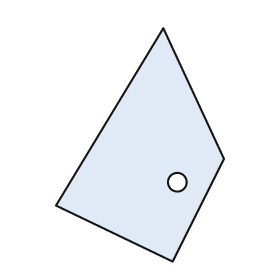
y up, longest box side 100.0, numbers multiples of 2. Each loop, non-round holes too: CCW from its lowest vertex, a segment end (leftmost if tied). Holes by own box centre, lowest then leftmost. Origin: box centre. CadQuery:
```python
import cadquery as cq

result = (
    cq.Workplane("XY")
    .moveTo(14.0, -50.0)
    .lineTo(36.0, -6.0)
    .lineTo(10.0, 50.0)
    .lineTo(-36.0, -26.0)
    .close()
    .moveTo(16.0, -16.0)
    .circle(4.0)
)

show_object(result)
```